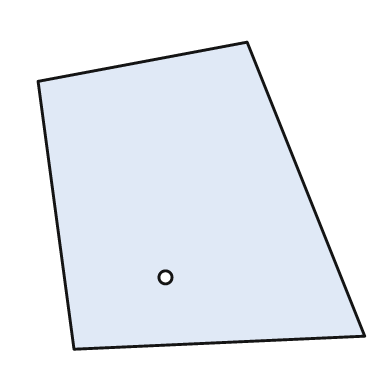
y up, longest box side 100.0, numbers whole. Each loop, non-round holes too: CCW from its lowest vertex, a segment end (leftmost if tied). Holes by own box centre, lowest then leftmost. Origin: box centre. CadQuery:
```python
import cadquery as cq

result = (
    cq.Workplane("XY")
    .moveTo(-39.0, -47.0)
    .lineTo(50.0, -43.0)
    .lineTo(14.0, 47.0)
    .lineTo(-50.0, 35.0)
    .close()
    .moveTo(-11.0, -25.0)
    .circle(2.0)
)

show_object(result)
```